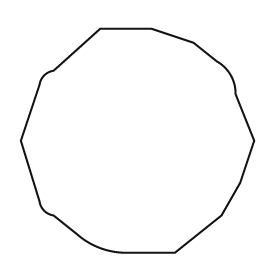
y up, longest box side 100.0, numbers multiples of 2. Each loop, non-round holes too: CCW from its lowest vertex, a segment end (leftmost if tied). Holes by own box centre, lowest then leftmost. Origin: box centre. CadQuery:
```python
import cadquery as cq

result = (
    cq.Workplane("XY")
    .moveTo(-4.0, -48.0)
    .lineTo(16.0, -48.0)
    .lineTo(36.0, -32.0)
    .lineTo(44.0, -18.0)
    .lineTo(50.0, 0.0)
    .lineTo(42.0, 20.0)
    .threePointArc((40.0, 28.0), (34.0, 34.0))
    .lineTo(24.0, 42.0)
    .lineTo(6.0, 48.0)
    .lineTo(-16.0, 48.0)
    .lineTo(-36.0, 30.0)
    .threePointArc((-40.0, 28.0), (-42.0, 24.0))
    .lineTo(-50.0, 0.0)
    .lineTo(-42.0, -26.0)
    .threePointArc((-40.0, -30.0), (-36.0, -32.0))
    .lineTo(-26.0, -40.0)
    .threePointArc((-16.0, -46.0), (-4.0, -48.0))
    .close()
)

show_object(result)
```